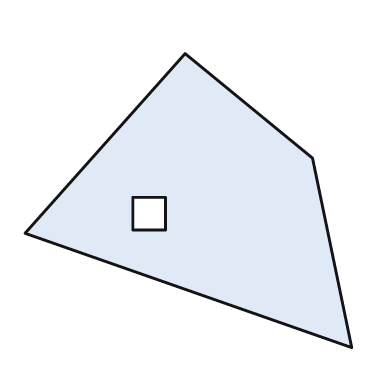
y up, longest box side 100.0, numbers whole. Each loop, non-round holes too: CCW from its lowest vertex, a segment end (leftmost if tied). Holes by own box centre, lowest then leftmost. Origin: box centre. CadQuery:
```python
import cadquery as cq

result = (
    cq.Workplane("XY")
    .moveTo(50.0, -45.0)
    .lineTo(38.0, 13.0)
    .lineTo(-1.0, 45.0)
    .lineTo(-50.0, -10.0)
    .close()
    .moveTo(-17.0, -9.0)
    .lineTo(-7.0, -9.0)
    .lineTo(-7.0, 1.0)
    .lineTo(-17.0, 1.0)
    .close()
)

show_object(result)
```